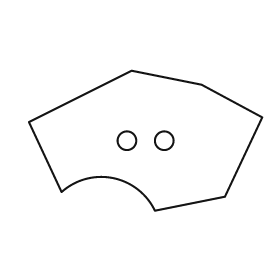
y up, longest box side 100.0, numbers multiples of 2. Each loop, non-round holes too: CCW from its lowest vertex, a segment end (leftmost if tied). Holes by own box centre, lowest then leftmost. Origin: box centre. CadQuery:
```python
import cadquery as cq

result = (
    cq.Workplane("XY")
    .moveTo(4.0, -30.0)
    .lineTo(34.0, -24.0)
    .lineTo(50.0, 10.0)
    .lineTo(24.0, 24.0)
    .lineTo(-6.0, 30.0)
    .lineTo(-50.0, 8.0)
    .lineTo(-36.0, -22.0)
    .threePointArc((-14.0, -16.0), (4.0, -30.0))
    .close()
    .moveTo(-8.0, 0.0)
    .circle(4.0)
    .moveTo(8.0, 0.0)
    .circle(4.0)
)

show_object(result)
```